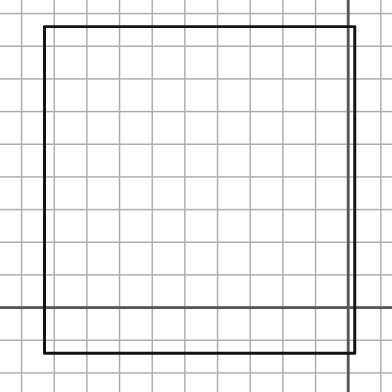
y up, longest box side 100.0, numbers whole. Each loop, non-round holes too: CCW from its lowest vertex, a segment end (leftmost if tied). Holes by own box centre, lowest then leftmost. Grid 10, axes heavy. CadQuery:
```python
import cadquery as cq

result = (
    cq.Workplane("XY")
    .moveTo(-93.0, -14.0)
    .lineTo(2.0, -14.0)
    .lineTo(2.0, 86.0)
    .lineTo(-93.0, 86.0)
    .close()
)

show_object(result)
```